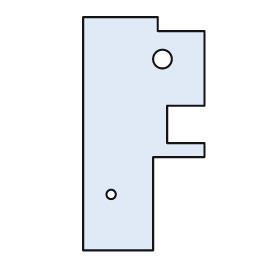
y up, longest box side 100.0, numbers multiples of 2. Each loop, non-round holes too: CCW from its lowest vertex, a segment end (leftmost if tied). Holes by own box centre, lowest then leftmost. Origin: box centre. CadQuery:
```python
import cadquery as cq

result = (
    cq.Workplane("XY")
    .moveTo(-26.0, -50.0)
    .lineTo(4.0, -50.0)
    .lineTo(4.0, -10.0)
    .lineTo(26.0, -10.0)
    .lineTo(26.0, -4.0)
    .lineTo(10.0, -4.0)
    .lineTo(10.0, 12.0)
    .lineTo(26.0, 12.0)
    .lineTo(26.0, 44.0)
    .lineTo(6.0, 44.0)
    .lineTo(6.0, 50.0)
    .lineTo(-26.0, 50.0)
    .close()
    .moveTo(-14.0, -26.0)
    .circle(2.0)
    .moveTo(8.0, 32.0)
    .circle(4.0)
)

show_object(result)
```